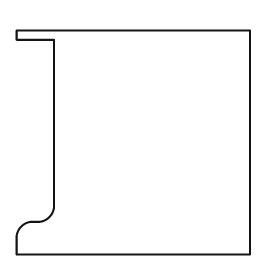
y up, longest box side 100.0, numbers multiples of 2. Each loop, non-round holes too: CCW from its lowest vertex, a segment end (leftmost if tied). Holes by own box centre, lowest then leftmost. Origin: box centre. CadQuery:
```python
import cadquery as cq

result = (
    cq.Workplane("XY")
    .moveTo(-50.0, -48.0)
    .lineTo(50.0, -48.0)
    .lineTo(50.0, 48.0)
    .lineTo(-50.0, 48.0)
    .lineTo(-50.0, 44.0)
    .lineTo(-34.0, 44.0)
    .lineTo(-34.0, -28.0)
    .threePointArc((-36.0, -32.0), (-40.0, -34.0))
    .lineTo(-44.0, -34.0)
    .threePointArc((-48.0, -36.0), (-50.0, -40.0))
    .close()
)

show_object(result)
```